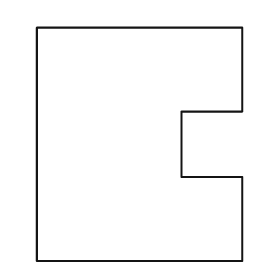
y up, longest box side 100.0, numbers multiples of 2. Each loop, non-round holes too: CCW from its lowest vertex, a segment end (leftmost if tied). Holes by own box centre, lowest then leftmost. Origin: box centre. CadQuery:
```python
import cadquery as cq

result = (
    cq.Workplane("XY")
    .moveTo(-44.0, -50.0)
    .lineTo(44.0, -50.0)
    .lineTo(44.0, -14.0)
    .lineTo(18.0, -14.0)
    .lineTo(18.0, 14.0)
    .lineTo(44.0, 14.0)
    .lineTo(44.0, 50.0)
    .lineTo(-44.0, 50.0)
    .close()
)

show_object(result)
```